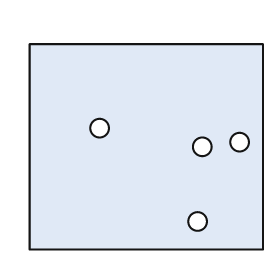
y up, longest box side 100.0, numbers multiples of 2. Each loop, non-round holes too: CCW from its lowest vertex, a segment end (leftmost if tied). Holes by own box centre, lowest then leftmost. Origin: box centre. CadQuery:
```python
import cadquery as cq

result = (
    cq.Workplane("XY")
    .moveTo(-50.0, -44.0)
    .lineTo(50.0, -44.0)
    .lineTo(50.0, 44.0)
    .lineTo(-50.0, 44.0)
    .close()
    .moveTo(22.0, -32.0)
    .circle(4.0)
    .moveTo(24.0, 0.0)
    .circle(4.0)
    .moveTo(40.0, 2.0)
    .circle(4.0)
    .moveTo(-20.0, 8.0)
    .circle(4.0)
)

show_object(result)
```